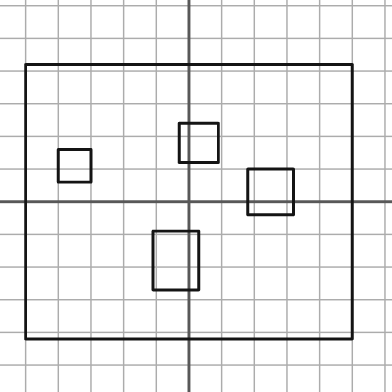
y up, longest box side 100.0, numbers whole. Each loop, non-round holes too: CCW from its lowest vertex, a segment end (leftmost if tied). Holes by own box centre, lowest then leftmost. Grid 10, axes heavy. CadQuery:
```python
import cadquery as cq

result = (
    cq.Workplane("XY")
    .moveTo(-50.0, -42.0)
    .lineTo(50.0, -42.0)
    .lineTo(50.0, 42.0)
    .lineTo(-50.0, 42.0)
    .close()
    .moveTo(-11.0, -27.0)
    .lineTo(3.0, -27.0)
    .lineTo(3.0, -9.0)
    .lineTo(-11.0, -9.0)
    .close()
    .moveTo(18.0, -4.0)
    .lineTo(32.0, -4.0)
    .lineTo(32.0, 10.0)
    .lineTo(18.0, 10.0)
    .close()
    .moveTo(-40.0, 6.0)
    .lineTo(-30.0, 6.0)
    .lineTo(-30.0, 16.0)
    .lineTo(-40.0, 16.0)
    .close()
    .moveTo(-3.0, 12.0)
    .lineTo(9.0, 12.0)
    .lineTo(9.0, 24.0)
    .lineTo(-3.0, 24.0)
    .close()
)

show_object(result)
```